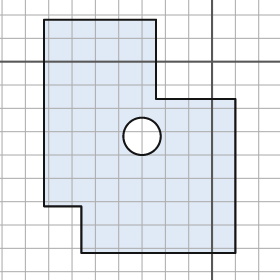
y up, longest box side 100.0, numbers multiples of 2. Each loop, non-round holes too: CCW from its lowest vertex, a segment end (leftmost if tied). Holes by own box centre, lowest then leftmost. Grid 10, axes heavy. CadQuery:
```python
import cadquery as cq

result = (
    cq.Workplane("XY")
    .moveTo(-56.0, -82.0)
    .lineTo(10.0, -82.0)
    .lineTo(10.0, -16.0)
    .lineTo(-24.0, -16.0)
    .lineTo(-24.0, 18.0)
    .lineTo(-72.0, 18.0)
    .lineTo(-72.0, -62.0)
    .lineTo(-56.0, -62.0)
    .close()
    .moveTo(-30.0, -32.0)
    .circle(8.0)
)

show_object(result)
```